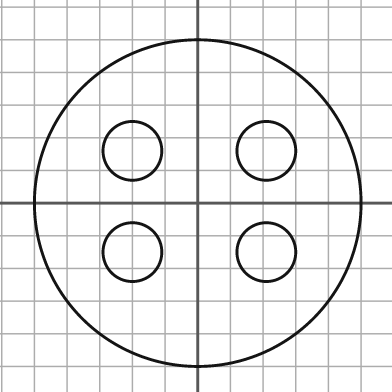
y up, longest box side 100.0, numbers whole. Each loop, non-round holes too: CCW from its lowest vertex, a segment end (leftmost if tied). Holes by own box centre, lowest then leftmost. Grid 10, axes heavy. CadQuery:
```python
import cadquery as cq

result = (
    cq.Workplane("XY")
    .moveTo(0.0, 0.0)
    .circle(50.0)
    .moveTo(-20.0, -15.0)
    .circle(9.0)
    .moveTo(21.0, -15.0)
    .circle(9.0)
    .moveTo(-20.0, 16.0)
    .circle(9.0)
    .moveTo(21.0, 16.0)
    .circle(9.0)
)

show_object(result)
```